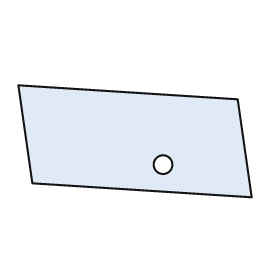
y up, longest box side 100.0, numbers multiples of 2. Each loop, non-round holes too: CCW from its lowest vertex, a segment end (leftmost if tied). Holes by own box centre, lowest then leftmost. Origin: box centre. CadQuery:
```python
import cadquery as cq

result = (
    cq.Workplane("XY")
    .moveTo(50.0, -24.0)
    .lineTo(44.0, 18.0)
    .lineTo(-50.0, 24.0)
    .lineTo(-44.0, -18.0)
    .close()
    .moveTo(12.0, -10.0)
    .circle(4.0)
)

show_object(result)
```